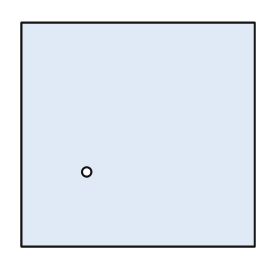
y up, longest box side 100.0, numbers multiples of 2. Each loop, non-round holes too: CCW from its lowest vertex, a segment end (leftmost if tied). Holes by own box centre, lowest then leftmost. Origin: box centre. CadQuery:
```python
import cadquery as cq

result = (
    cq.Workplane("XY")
    .moveTo(-50.0, -48.0)
    .lineTo(50.0, -48.0)
    .lineTo(50.0, 48.0)
    .lineTo(-50.0, 48.0)
    .close()
    .moveTo(-22.0, -16.0)
    .circle(2.0)
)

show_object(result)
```